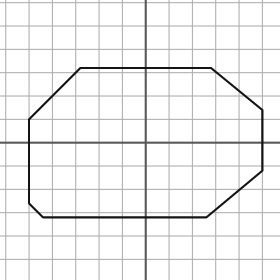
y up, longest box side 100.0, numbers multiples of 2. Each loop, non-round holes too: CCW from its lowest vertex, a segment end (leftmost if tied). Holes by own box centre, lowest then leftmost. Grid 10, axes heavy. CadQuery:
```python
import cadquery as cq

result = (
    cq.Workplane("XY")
    .moveTo(-44.0, -32.0)
    .lineTo(26.0, -32.0)
    .lineTo(50.0, -12.0)
    .lineTo(50.0, 14.0)
    .lineTo(28.0, 32.0)
    .lineTo(-28.0, 32.0)
    .lineTo(-50.0, 10.0)
    .lineTo(-50.0, -26.0)
    .close()
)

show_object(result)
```